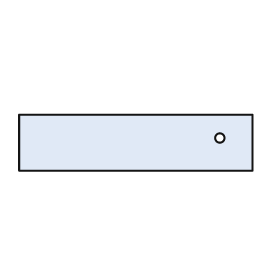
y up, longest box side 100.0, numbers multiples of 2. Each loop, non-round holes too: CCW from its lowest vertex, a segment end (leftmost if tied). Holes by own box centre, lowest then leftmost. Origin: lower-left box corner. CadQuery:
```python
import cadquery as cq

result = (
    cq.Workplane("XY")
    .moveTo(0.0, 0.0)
    .lineTo(100.0, 0.0)
    .lineTo(100.0, 24.0)
    .lineTo(0.0, 24.0)
    .close()
    .moveTo(86.0, 14.0)
    .circle(2.0)
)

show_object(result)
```